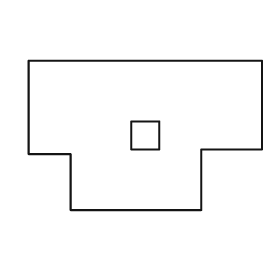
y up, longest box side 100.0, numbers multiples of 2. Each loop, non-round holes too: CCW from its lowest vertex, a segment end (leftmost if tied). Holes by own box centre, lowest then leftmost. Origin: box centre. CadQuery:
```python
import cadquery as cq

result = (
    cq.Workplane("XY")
    .moveTo(-32.0, -32.0)
    .lineTo(24.0, -32.0)
    .lineTo(24.0, -6.0)
    .lineTo(50.0, -6.0)
    .lineTo(50.0, 32.0)
    .lineTo(-50.0, 32.0)
    .lineTo(-50.0, -8.0)
    .lineTo(-32.0, -8.0)
    .close()
    .moveTo(-6.0, -6.0)
    .lineTo(6.0, -6.0)
    .lineTo(6.0, 6.0)
    .lineTo(-6.0, 6.0)
    .close()
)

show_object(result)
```